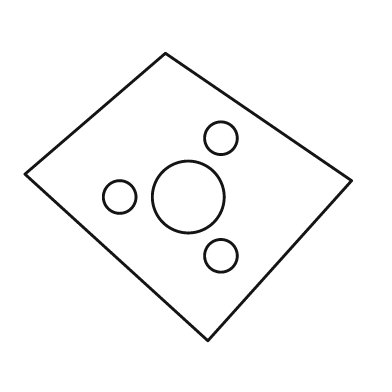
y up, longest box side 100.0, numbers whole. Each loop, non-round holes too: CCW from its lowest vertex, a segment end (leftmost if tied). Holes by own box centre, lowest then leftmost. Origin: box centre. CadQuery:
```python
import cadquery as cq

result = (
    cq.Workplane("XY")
    .moveTo(6.0, -44.0)
    .lineTo(50.0, 5.0)
    .lineTo(-7.0, 44.0)
    .lineTo(-50.0, 7.0)
    .close()
    .moveTo(10.0, -18.0)
    .circle(5.0)
    .moveTo(-21.0, 0.0)
    .circle(5.0)
    .moveTo(0.0, 0.0)
    .circle(11.0)
    .moveTo(10.0, 18.0)
    .circle(5.0)
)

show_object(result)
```